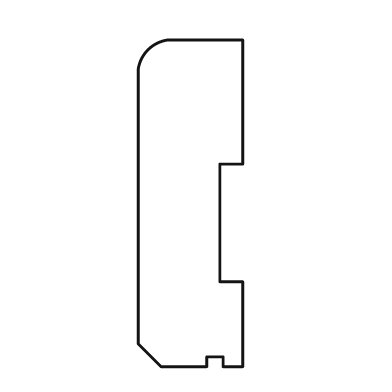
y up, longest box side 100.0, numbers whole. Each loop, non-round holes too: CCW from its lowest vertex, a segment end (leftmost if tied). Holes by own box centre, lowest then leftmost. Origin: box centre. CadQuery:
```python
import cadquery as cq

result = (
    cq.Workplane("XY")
    .moveTo(-9.0, -50.0)
    .lineTo(5.0, -50.0)
    .lineTo(5.0, -47.0)
    .lineTo(10.0, -47.0)
    .lineTo(10.0, -50.0)
    .lineTo(16.0, -50.0)
    .lineTo(16.0, -24.0)
    .lineTo(9.0, -24.0)
    .lineTo(9.0, 12.0)
    .lineTo(16.0, 12.0)
    .lineTo(16.0, 50.0)
    .lineTo(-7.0, 50.0)
    .threePointArc((-13.0, 47.0), (-16.0, 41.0))
    .lineTo(-16.0, -43.0)
    .close()
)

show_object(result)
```